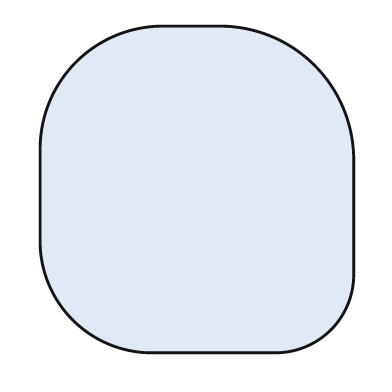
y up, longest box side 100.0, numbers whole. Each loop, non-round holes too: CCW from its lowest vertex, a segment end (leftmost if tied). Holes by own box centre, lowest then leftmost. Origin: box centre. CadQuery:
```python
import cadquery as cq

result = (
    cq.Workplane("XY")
    .moveTo(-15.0, -50.0)
    .lineTo(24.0, -50.0)
    .threePointArc((41.0, -43.0), (48.0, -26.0))
    .lineTo(48.0, 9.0)
    .threePointArc((36.0, 38.0), (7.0, 50.0))
    .lineTo(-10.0, 50.0)
    .threePointArc((-37.0, 39.0), (-48.0, 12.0))
    .lineTo(-48.0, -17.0)
    .threePointArc((-38.0, -40.0), (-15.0, -50.0))
    .close()
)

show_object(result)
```